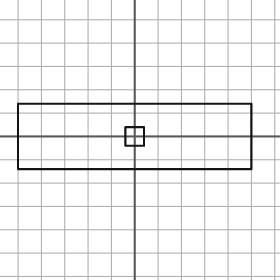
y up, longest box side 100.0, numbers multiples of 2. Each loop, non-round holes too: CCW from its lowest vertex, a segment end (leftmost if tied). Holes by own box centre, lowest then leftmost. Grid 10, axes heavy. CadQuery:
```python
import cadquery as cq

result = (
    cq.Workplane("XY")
    .moveTo(-50.0, -14.0)
    .lineTo(50.0, -14.0)
    .lineTo(50.0, 14.0)
    .lineTo(-50.0, 14.0)
    .close()
    .moveTo(-4.0, -4.0)
    .lineTo(4.0, -4.0)
    .lineTo(4.0, 4.0)
    .lineTo(-4.0, 4.0)
    .close()
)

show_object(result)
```